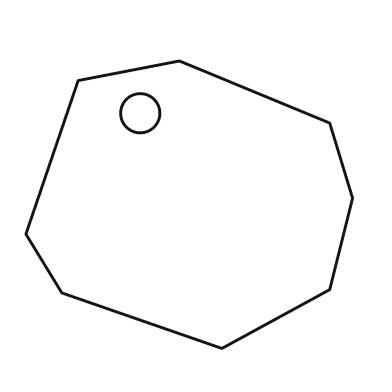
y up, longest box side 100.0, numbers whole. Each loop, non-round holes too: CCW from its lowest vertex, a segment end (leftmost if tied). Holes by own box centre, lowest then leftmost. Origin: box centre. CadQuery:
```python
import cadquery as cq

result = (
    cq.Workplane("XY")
    .moveTo(10.0, -44.0)
    .lineTo(43.0, -26.0)
    .lineTo(50.0, 2.0)
    .lineTo(43.0, 25.0)
    .lineTo(-3.0, 44.0)
    .lineTo(-34.0, 38.0)
    .lineTo(-50.0, -9.0)
    .lineTo(-39.0, -27.0)
    .close()
    .moveTo(-15.0, 28.0)
    .circle(6.0)
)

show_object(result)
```